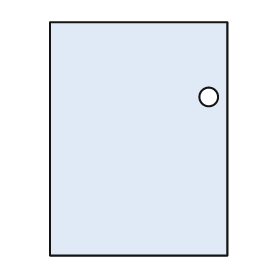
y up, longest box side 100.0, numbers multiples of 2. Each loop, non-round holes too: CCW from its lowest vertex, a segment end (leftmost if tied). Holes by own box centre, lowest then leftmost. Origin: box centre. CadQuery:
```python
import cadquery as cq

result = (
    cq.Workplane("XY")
    .moveTo(-38.0, -50.0)
    .lineTo(38.0, -50.0)
    .lineTo(38.0, 50.0)
    .lineTo(-38.0, 50.0)
    .close()
    .moveTo(30.0, 18.0)
    .circle(4.0)
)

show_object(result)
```